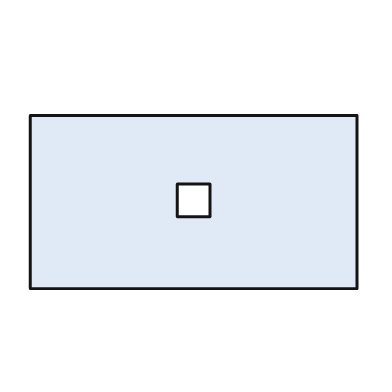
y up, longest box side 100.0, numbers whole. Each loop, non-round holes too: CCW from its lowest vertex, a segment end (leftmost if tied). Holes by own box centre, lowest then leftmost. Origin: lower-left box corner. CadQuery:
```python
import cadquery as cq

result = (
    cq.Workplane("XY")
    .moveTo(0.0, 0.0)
    .lineTo(100.0, 0.0)
    .lineTo(100.0, 53.0)
    .lineTo(0.0, 53.0)
    .close()
    .moveTo(45.0, 22.0)
    .lineTo(55.0, 22.0)
    .lineTo(55.0, 32.0)
    .lineTo(45.0, 32.0)
    .close()
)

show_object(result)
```